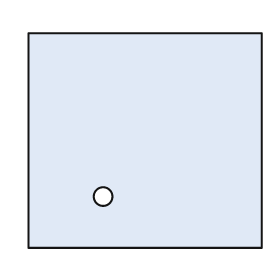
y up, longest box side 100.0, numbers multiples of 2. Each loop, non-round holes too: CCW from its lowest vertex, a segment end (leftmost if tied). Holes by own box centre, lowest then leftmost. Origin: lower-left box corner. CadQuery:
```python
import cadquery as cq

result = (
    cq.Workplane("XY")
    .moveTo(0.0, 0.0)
    .lineTo(100.0, 0.0)
    .lineTo(100.0, 92.0)
    .lineTo(0.0, 92.0)
    .close()
    .moveTo(32.0, 22.0)
    .circle(4.0)
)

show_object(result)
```